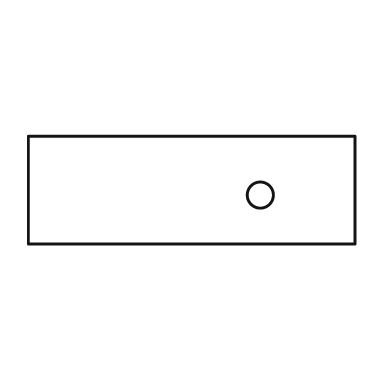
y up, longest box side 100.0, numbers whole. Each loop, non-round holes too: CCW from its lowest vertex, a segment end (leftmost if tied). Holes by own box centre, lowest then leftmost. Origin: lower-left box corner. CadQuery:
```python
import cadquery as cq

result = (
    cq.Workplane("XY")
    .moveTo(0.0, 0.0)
    .lineTo(100.0, 0.0)
    .lineTo(100.0, 33.0)
    .lineTo(0.0, 33.0)
    .close()
    .moveTo(71.0, 15.0)
    .circle(4.0)
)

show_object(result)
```